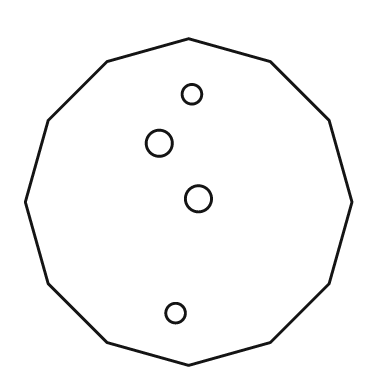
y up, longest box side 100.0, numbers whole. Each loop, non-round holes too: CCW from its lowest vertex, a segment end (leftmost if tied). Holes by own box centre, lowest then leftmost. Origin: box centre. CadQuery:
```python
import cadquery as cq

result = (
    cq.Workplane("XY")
    .moveTo(0.0, -50.0)
    .lineTo(25.0, -43.0)
    .lineTo(43.0, -25.0)
    .lineTo(50.0, 0.0)
    .lineTo(43.0, 25.0)
    .lineTo(25.0, 43.0)
    .lineTo(0.0, 50.0)
    .lineTo(-25.0, 43.0)
    .lineTo(-43.0, 25.0)
    .lineTo(-50.0, 0.0)
    .lineTo(-43.0, -25.0)
    .lineTo(-25.0, -43.0)
    .close()
    .moveTo(-4.0, -34.0)
    .circle(3.0)
    .moveTo(3.0, 1.0)
    .circle(4.0)
    .moveTo(-9.0, 18.0)
    .circle(4.0)
    .moveTo(1.0, 33.0)
    .circle(3.0)
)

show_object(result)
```